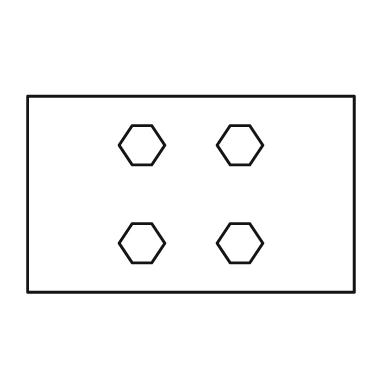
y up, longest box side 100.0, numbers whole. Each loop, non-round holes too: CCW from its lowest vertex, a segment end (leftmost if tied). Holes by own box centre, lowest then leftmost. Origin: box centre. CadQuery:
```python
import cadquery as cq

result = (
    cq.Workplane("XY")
    .moveTo(-50.0, -30.0)
    .lineTo(50.0, -30.0)
    .lineTo(50.0, 30.0)
    .lineTo(-50.0, 30.0)
    .close()
    .moveTo(-18.0, -21.0)
    .lineTo(-12.0, -21.0)
    .lineTo(-8.0, -15.0)
    .lineTo(-12.0, -9.0)
    .lineTo(-18.0, -9.0)
    .lineTo(-22.0, -15.0)
    .close()
    .moveTo(12.0, -21.0)
    .lineTo(18.0, -21.0)
    .lineTo(22.0, -15.0)
    .lineTo(18.0, -9.0)
    .lineTo(12.0, -9.0)
    .lineTo(8.0, -15.0)
    .close()
    .moveTo(-18.0, 9.0)
    .lineTo(-12.0, 9.0)
    .lineTo(-8.0, 15.0)
    .lineTo(-12.0, 21.0)
    .lineTo(-18.0, 21.0)
    .lineTo(-22.0, 15.0)
    .close()
    .moveTo(12.0, 9.0)
    .lineTo(18.0, 9.0)
    .lineTo(22.0, 15.0)
    .lineTo(18.0, 21.0)
    .lineTo(12.0, 21.0)
    .lineTo(8.0, 15.0)
    .close()
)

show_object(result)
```